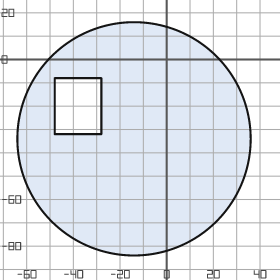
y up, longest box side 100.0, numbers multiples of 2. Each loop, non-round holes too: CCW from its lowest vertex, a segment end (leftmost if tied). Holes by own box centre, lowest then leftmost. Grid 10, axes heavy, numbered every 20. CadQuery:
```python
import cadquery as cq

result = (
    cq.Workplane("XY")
    .moveTo(-14.0, -34.0)
    .circle(50.0)
    .moveTo(-48.0, -32.0)
    .lineTo(-28.0, -32.0)
    .lineTo(-28.0, -8.0)
    .lineTo(-48.0, -8.0)
    .close()
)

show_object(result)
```